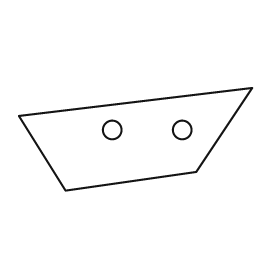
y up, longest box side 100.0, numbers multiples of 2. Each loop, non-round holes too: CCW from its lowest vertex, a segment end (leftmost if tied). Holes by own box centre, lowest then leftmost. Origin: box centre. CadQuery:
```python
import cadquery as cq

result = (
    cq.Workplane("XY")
    .moveTo(-30.0, -22.0)
    .lineTo(26.0, -14.0)
    .lineTo(50.0, 22.0)
    .lineTo(-50.0, 10.0)
    .close()
    .moveTo(-10.0, 4.0)
    .circle(4.0)
    .moveTo(20.0, 4.0)
    .circle(4.0)
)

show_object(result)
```